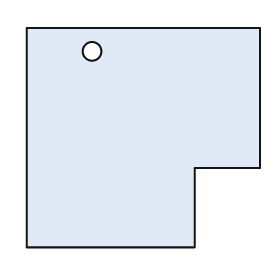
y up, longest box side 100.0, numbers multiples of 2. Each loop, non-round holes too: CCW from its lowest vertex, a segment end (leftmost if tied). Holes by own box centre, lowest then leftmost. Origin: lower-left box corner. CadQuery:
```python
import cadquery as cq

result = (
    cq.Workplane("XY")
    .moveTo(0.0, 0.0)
    .lineTo(72.0, 0.0)
    .lineTo(72.0, 34.0)
    .lineTo(100.0, 34.0)
    .lineTo(100.0, 94.0)
    .lineTo(0.0, 94.0)
    .close()
    .moveTo(28.0, 84.0)
    .circle(4.0)
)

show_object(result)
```